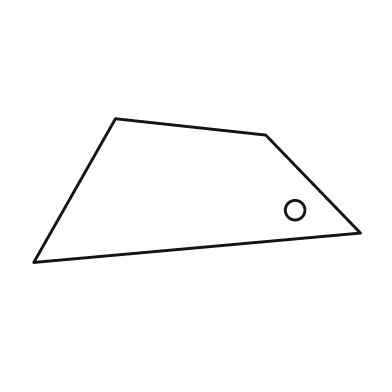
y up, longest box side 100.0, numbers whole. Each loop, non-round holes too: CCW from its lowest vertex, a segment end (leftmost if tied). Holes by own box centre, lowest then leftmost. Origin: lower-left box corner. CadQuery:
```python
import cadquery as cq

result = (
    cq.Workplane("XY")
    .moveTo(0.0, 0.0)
    .lineTo(100.0, 9.0)
    .lineTo(71.0, 39.0)
    .lineTo(25.0, 44.0)
    .close()
    .moveTo(80.0, 16.0)
    .circle(3.0)
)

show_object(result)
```